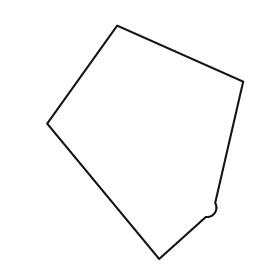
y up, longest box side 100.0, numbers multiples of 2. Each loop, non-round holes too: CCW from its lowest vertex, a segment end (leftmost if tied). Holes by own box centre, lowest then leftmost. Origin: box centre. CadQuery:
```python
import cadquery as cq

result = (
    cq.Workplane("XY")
    .moveTo(6.0, -50.0)
    .lineTo(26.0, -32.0)
    .threePointArc((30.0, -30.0), (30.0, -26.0))
    .lineTo(42.0, 26.0)
    .lineTo(-12.0, 50.0)
    .lineTo(-42.0, 8.0)
    .close()
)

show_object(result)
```